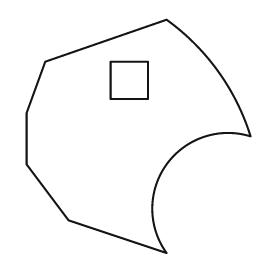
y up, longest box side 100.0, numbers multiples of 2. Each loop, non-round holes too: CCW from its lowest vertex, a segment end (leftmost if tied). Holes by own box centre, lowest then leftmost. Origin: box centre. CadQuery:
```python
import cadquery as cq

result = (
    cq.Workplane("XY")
    .moveTo(12.0, -50.0)
    .threePointArc((12.0, -12.0), (48.0, 0.0))
    .threePointArc((34.0, 28.0), (12.0, 50.0))
    .lineTo(-40.0, 32.0)
    .lineTo(-48.0, 10.0)
    .lineTo(-48.0, -12.0)
    .lineTo(-30.0, -36.0)
    .close()
    .moveTo(-12.0, 16.0)
    .lineTo(4.0, 16.0)
    .lineTo(4.0, 32.0)
    .lineTo(-12.0, 32.0)
    .close()
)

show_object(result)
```